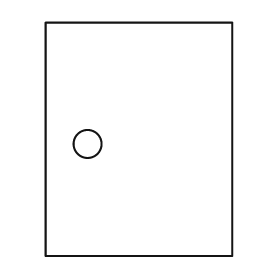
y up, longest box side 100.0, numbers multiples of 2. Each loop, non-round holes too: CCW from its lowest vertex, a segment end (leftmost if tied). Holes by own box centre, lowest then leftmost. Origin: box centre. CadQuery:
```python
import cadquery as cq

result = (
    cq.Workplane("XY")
    .moveTo(-40.0, -50.0)
    .lineTo(40.0, -50.0)
    .lineTo(40.0, 50.0)
    .lineTo(-40.0, 50.0)
    .close()
    .moveTo(-22.0, -2.0)
    .circle(6.0)
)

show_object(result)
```